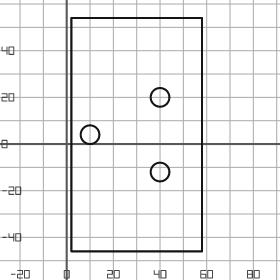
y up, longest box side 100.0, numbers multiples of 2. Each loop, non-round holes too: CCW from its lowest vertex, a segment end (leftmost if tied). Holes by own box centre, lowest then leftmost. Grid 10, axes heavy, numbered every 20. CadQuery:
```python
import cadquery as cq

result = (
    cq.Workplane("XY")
    .moveTo(2.0, -46.0)
    .lineTo(58.0, -46.0)
    .lineTo(58.0, 54.0)
    .lineTo(2.0, 54.0)
    .close()
    .moveTo(40.0, -12.0)
    .circle(4.0)
    .moveTo(10.0, 4.0)
    .circle(4.0)
    .moveTo(40.0, 20.0)
    .circle(4.0)
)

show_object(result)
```